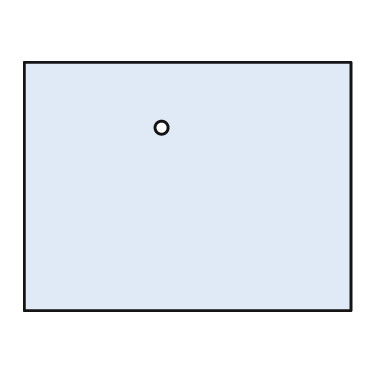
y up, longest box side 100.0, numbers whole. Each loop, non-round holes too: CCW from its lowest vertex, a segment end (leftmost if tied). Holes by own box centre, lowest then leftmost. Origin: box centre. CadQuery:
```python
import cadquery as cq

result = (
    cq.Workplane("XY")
    .moveTo(-50.0, -38.0)
    .lineTo(50.0, -38.0)
    .lineTo(50.0, 38.0)
    .lineTo(-50.0, 38.0)
    .close()
    .moveTo(-8.0, 18.0)
    .circle(2.0)
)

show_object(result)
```